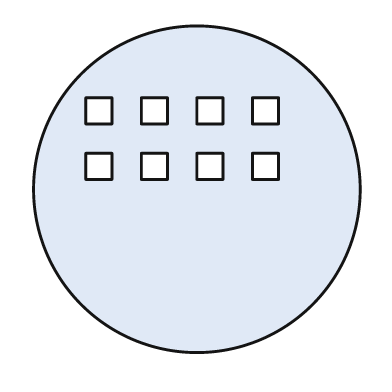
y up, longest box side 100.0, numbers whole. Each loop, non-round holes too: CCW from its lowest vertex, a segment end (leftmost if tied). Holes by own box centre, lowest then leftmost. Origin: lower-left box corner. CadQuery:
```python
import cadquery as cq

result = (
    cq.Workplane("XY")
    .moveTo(50.0, 50.0)
    .circle(50.0)
    .moveTo(16.0, 53.0)
    .lineTo(24.0, 53.0)
    .lineTo(24.0, 61.0)
    .lineTo(16.0, 61.0)
    .close()
    .moveTo(33.0, 53.0)
    .lineTo(41.0, 53.0)
    .lineTo(41.0, 61.0)
    .lineTo(33.0, 61.0)
    .close()
    .moveTo(50.0, 53.0)
    .lineTo(58.0, 53.0)
    .lineTo(58.0, 61.0)
    .lineTo(50.0, 61.0)
    .close()
    .moveTo(67.0, 53.0)
    .lineTo(75.0, 53.0)
    .lineTo(75.0, 61.0)
    .lineTo(67.0, 61.0)
    .close()
    .moveTo(16.0, 70.0)
    .lineTo(24.0, 70.0)
    .lineTo(24.0, 78.0)
    .lineTo(16.0, 78.0)
    .close()
    .moveTo(33.0, 70.0)
    .lineTo(41.0, 70.0)
    .lineTo(41.0, 78.0)
    .lineTo(33.0, 78.0)
    .close()
    .moveTo(50.0, 70.0)
    .lineTo(58.0, 70.0)
    .lineTo(58.0, 78.0)
    .lineTo(50.0, 78.0)
    .close()
    .moveTo(67.0, 70.0)
    .lineTo(75.0, 70.0)
    .lineTo(75.0, 78.0)
    .lineTo(67.0, 78.0)
    .close()
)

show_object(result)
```